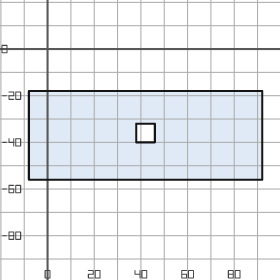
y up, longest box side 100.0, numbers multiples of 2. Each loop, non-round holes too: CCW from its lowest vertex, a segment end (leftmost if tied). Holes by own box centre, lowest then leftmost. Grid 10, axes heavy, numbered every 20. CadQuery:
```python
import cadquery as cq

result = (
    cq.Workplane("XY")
    .moveTo(-8.0, -56.0)
    .lineTo(92.0, -56.0)
    .lineTo(92.0, -18.0)
    .lineTo(-8.0, -18.0)
    .close()
    .moveTo(38.0, -40.0)
    .lineTo(46.0, -40.0)
    .lineTo(46.0, -32.0)
    .lineTo(38.0, -32.0)
    .close()
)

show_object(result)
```